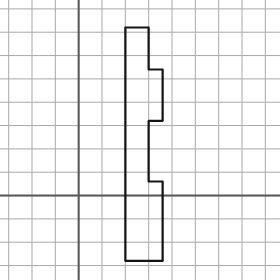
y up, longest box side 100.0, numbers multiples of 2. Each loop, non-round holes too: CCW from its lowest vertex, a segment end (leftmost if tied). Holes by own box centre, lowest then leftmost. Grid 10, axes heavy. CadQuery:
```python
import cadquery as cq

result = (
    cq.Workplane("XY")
    .moveTo(20.0, -28.0)
    .lineTo(36.0, -28.0)
    .lineTo(36.0, 6.0)
    .lineTo(30.0, 6.0)
    .lineTo(30.0, 32.0)
    .lineTo(36.0, 32.0)
    .lineTo(36.0, 54.0)
    .lineTo(30.0, 54.0)
    .lineTo(30.0, 72.0)
    .lineTo(20.0, 72.0)
    .close()
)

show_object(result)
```